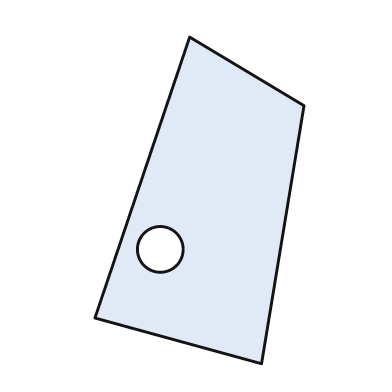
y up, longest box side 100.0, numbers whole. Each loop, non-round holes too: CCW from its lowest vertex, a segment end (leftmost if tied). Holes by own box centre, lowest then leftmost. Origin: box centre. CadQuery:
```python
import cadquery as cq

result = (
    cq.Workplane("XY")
    .moveTo(19.0, -50.0)
    .lineTo(32.0, 29.0)
    .lineTo(-3.0, 50.0)
    .lineTo(-32.0, -36.0)
    .close()
    .moveTo(-12.0, -15.0)
    .circle(7.0)
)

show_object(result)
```